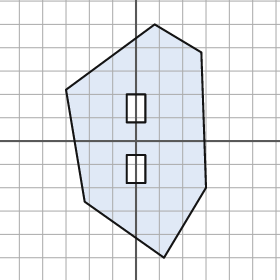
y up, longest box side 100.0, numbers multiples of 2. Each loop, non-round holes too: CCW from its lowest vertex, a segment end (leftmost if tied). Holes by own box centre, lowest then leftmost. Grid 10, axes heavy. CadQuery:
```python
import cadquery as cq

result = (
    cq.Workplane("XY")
    .moveTo(12.0, -50.0)
    .lineTo(30.0, -20.0)
    .lineTo(28.0, 38.0)
    .lineTo(8.0, 50.0)
    .lineTo(-30.0, 22.0)
    .lineTo(-22.0, -26.0)
    .close()
    .moveTo(-4.0, -18.0)
    .lineTo(4.0, -18.0)
    .lineTo(4.0, -6.0)
    .lineTo(-4.0, -6.0)
    .close()
    .moveTo(-4.0, 8.0)
    .lineTo(4.0, 8.0)
    .lineTo(4.0, 20.0)
    .lineTo(-4.0, 20.0)
    .close()
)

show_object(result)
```